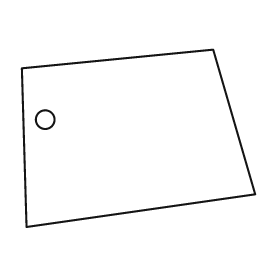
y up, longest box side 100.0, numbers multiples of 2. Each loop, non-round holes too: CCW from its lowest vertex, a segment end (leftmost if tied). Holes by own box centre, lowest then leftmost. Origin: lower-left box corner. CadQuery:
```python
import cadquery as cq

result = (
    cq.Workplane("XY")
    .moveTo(2.0, 0.0)
    .lineTo(100.0, 14.0)
    .lineTo(82.0, 76.0)
    .lineTo(0.0, 68.0)
    .close()
    .moveTo(10.0, 46.0)
    .circle(4.0)
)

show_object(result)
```